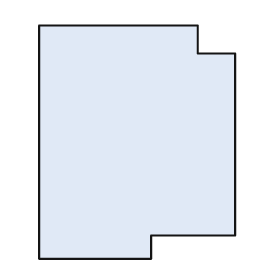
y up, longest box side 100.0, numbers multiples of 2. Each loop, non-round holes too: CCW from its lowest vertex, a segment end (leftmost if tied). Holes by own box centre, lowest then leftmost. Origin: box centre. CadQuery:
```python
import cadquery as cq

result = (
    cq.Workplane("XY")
    .moveTo(-42.0, -50.0)
    .lineTo(6.0, -50.0)
    .lineTo(6.0, -40.0)
    .lineTo(42.0, -40.0)
    .lineTo(42.0, 38.0)
    .lineTo(26.0, 38.0)
    .lineTo(26.0, 50.0)
    .lineTo(-42.0, 50.0)
    .close()
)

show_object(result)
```